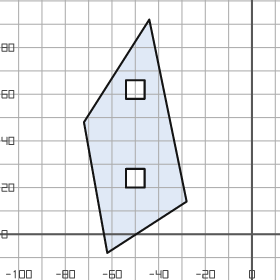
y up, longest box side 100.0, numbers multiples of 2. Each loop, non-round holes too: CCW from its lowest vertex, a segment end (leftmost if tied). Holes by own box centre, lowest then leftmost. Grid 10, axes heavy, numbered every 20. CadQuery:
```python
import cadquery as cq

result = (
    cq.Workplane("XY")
    .moveTo(-62.0, -8.0)
    .lineTo(-28.0, 14.0)
    .lineTo(-44.0, 92.0)
    .lineTo(-72.0, 48.0)
    .close()
    .moveTo(-54.0, 20.0)
    .lineTo(-46.0, 20.0)
    .lineTo(-46.0, 28.0)
    .lineTo(-54.0, 28.0)
    .close()
    .moveTo(-54.0, 58.0)
    .lineTo(-46.0, 58.0)
    .lineTo(-46.0, 66.0)
    .lineTo(-54.0, 66.0)
    .close()
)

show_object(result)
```